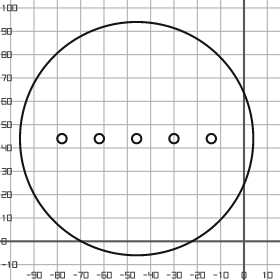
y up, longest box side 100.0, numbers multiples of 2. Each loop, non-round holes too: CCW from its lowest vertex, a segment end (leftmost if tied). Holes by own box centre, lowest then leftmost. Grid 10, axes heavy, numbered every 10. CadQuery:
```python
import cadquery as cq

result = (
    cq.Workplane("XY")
    .moveTo(-46.0, 44.0)
    .circle(50.0)
    .moveTo(-78.0, 44.0)
    .circle(2.0)
    .moveTo(-62.0, 44.0)
    .circle(2.0)
    .moveTo(-46.0, 44.0)
    .circle(2.0)
    .moveTo(-30.0, 44.0)
    .circle(2.0)
    .moveTo(-14.0, 44.0)
    .circle(2.0)
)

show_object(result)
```